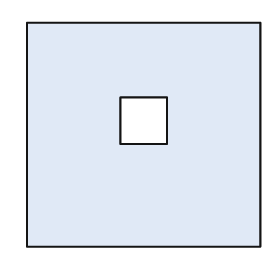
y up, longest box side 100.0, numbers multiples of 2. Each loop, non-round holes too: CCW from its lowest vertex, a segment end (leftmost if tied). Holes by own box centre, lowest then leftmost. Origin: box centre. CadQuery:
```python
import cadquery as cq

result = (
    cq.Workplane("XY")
    .moveTo(-50.0, -48.0)
    .lineTo(50.0, -48.0)
    .lineTo(50.0, 48.0)
    .lineTo(-50.0, 48.0)
    .close()
    .moveTo(-10.0, -4.0)
    .lineTo(10.0, -4.0)
    .lineTo(10.0, 16.0)
    .lineTo(-10.0, 16.0)
    .close()
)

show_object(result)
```